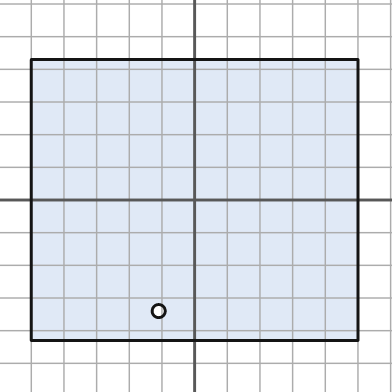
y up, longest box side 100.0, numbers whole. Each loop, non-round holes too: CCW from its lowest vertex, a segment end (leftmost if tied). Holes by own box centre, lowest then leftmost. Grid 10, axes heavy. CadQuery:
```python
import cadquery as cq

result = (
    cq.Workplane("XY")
    .moveTo(-50.0, -43.0)
    .lineTo(50.0, -43.0)
    .lineTo(50.0, 43.0)
    .lineTo(-50.0, 43.0)
    .close()
    .moveTo(-11.0, -34.0)
    .circle(2.0)
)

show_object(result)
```